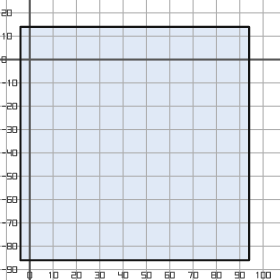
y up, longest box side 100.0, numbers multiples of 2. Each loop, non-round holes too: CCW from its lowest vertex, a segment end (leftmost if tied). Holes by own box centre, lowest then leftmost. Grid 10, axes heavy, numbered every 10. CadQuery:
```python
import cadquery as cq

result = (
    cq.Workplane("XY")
    .moveTo(-4.0, -86.0)
    .lineTo(94.0, -86.0)
    .lineTo(94.0, 14.0)
    .lineTo(-4.0, 14.0)
    .close()
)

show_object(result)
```